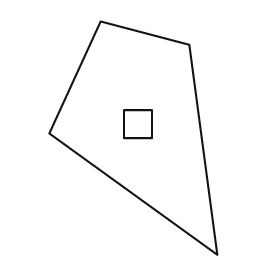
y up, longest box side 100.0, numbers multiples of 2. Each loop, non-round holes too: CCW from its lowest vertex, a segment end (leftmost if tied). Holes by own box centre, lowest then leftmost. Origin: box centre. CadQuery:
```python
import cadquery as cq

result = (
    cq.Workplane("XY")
    .moveTo(36.0, -50.0)
    .lineTo(24.0, 40.0)
    .lineTo(-14.0, 50.0)
    .lineTo(-36.0, 2.0)
    .close()
    .moveTo(-4.0, 0.0)
    .lineTo(8.0, 0.0)
    .lineTo(8.0, 12.0)
    .lineTo(-4.0, 12.0)
    .close()
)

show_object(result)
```